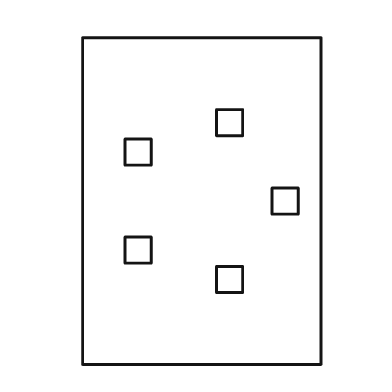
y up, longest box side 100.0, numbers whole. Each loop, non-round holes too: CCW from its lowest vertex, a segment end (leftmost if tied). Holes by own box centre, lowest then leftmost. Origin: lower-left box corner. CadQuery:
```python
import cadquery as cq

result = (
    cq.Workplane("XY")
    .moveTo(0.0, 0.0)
    .lineTo(73.0, 0.0)
    .lineTo(73.0, 100.0)
    .lineTo(0.0, 100.0)
    .close()
    .moveTo(41.0, 22.0)
    .lineTo(49.0, 22.0)
    .lineTo(49.0, 30.0)
    .lineTo(41.0, 30.0)
    .close()
    .moveTo(13.0, 31.0)
    .lineTo(21.0, 31.0)
    .lineTo(21.0, 39.0)
    .lineTo(13.0, 39.0)
    .close()
    .moveTo(58.0, 46.0)
    .lineTo(66.0, 46.0)
    .lineTo(66.0, 54.0)
    .lineTo(58.0, 54.0)
    .close()
    .moveTo(13.0, 61.0)
    .lineTo(21.0, 61.0)
    .lineTo(21.0, 69.0)
    .lineTo(13.0, 69.0)
    .close()
    .moveTo(41.0, 70.0)
    .lineTo(49.0, 70.0)
    .lineTo(49.0, 78.0)
    .lineTo(41.0, 78.0)
    .close()
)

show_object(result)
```